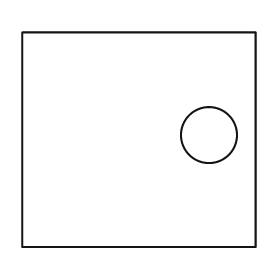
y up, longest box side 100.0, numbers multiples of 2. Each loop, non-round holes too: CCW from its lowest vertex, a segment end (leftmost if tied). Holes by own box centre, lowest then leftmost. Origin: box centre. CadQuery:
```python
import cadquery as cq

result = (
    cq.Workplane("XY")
    .moveTo(-50.0, -46.0)
    .lineTo(50.0, -46.0)
    .lineTo(50.0, 46.0)
    .lineTo(-50.0, 46.0)
    .close()
    .moveTo(30.0, 2.0)
    .circle(12.0)
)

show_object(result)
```